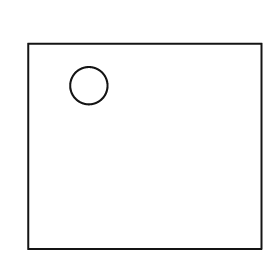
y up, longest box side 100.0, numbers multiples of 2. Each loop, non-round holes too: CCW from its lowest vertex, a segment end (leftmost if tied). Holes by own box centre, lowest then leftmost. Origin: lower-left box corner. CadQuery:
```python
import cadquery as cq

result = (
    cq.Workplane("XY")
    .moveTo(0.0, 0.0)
    .lineTo(100.0, 0.0)
    .lineTo(100.0, 88.0)
    .lineTo(0.0, 88.0)
    .close()
    .moveTo(26.0, 70.0)
    .circle(8.0)
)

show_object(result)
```